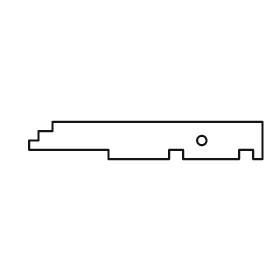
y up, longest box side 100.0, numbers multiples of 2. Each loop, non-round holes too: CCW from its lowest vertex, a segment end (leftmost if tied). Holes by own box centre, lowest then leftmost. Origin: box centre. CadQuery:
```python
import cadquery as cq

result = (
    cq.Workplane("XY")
    .moveTo(-16.0, -8.0)
    .lineTo(10.0, -8.0)
    .lineTo(10.0, -4.0)
    .lineTo(16.0, -4.0)
    .lineTo(16.0, -8.0)
    .lineTo(40.0, -8.0)
    .lineTo(40.0, -4.0)
    .lineTo(46.0, -4.0)
    .lineTo(46.0, -8.0)
    .lineTo(50.0, -8.0)
    .lineTo(50.0, 8.0)
    .lineTo(-40.0, 8.0)
    .lineTo(-40.0, 4.0)
    .lineTo(-46.0, 4.0)
    .lineTo(-46.0, 0.0)
    .lineTo(-50.0, 0.0)
    .lineTo(-50.0, -4.0)
    .lineTo(-16.0, -4.0)
    .close()
    .moveTo(24.0, 0.0)
    .circle(2.0)
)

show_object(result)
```